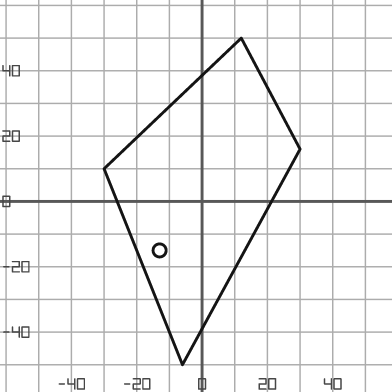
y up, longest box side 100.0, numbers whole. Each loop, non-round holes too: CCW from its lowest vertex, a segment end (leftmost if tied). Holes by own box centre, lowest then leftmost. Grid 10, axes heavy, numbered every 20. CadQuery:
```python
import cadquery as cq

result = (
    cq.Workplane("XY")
    .moveTo(-6.0, -50.0)
    .lineTo(30.0, 16.0)
    .lineTo(12.0, 50.0)
    .lineTo(-30.0, 10.0)
    .close()
    .moveTo(-13.0, -15.0)
    .circle(2.0)
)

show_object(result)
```